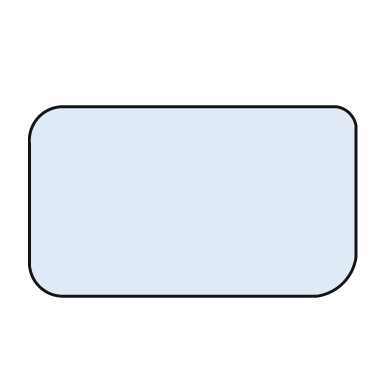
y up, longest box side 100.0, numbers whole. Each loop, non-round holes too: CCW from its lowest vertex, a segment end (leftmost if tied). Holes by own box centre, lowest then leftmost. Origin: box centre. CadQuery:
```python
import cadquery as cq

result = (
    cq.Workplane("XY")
    .moveTo(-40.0, -29.0)
    .lineTo(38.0, -29.0)
    .threePointArc((46.0, -25.0), (50.0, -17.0))
    .lineTo(50.0, 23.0)
    .threePointArc((48.0, 27.0), (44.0, 29.0))
    .lineTo(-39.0, 29.0)
    .threePointArc((-47.0, 26.0), (-50.0, 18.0))
    .lineTo(-50.0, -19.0)
    .threePointArc((-47.0, -26.0), (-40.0, -29.0))
    .close()
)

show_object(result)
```